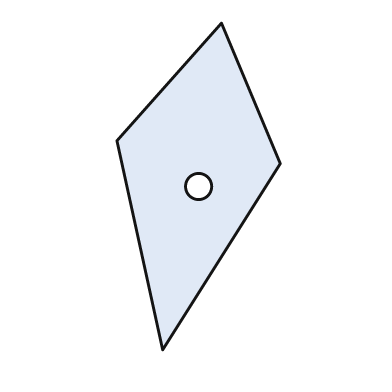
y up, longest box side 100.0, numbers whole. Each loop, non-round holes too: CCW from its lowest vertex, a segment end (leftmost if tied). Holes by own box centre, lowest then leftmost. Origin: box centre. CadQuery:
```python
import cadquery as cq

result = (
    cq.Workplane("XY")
    .moveTo(-11.0, -50.0)
    .lineTo(25.0, 7.0)
    .lineTo(7.0, 50.0)
    .lineTo(-25.0, 14.0)
    .close()
    .moveTo(0.0, 0.0)
    .circle(4.0)
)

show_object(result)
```